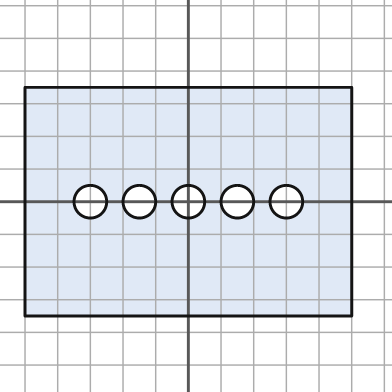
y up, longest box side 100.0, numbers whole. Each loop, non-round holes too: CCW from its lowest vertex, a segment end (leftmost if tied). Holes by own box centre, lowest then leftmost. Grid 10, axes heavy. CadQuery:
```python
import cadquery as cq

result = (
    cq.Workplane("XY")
    .moveTo(-50.0, -35.0)
    .lineTo(50.0, -35.0)
    .lineTo(50.0, 35.0)
    .lineTo(-50.0, 35.0)
    .close()
    .moveTo(-30.0, 0.0)
    .circle(5.0)
    .moveTo(-15.0, 0.0)
    .circle(5.0)
    .moveTo(0.0, 0.0)
    .circle(5.0)
    .moveTo(15.0, 0.0)
    .circle(5.0)
    .moveTo(30.0, 0.0)
    .circle(5.0)
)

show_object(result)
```